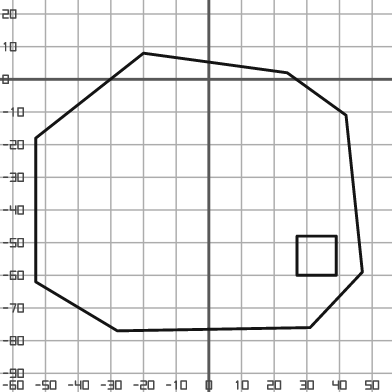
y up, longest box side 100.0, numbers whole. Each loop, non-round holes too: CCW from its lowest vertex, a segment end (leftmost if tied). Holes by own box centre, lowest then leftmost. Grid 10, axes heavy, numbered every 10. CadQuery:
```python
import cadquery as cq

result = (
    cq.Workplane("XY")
    .moveTo(-28.0, -77.0)
    .lineTo(31.0, -76.0)
    .lineTo(47.0, -59.0)
    .lineTo(42.0, -11.0)
    .lineTo(24.0, 2.0)
    .lineTo(-20.0, 8.0)
    .lineTo(-53.0, -18.0)
    .lineTo(-53.0, -62.0)
    .close()
    .moveTo(27.0, -60.0)
    .lineTo(39.0, -60.0)
    .lineTo(39.0, -48.0)
    .lineTo(27.0, -48.0)
    .close()
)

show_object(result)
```